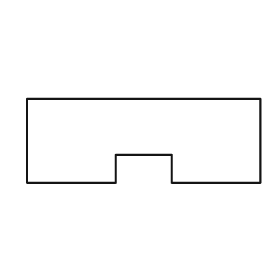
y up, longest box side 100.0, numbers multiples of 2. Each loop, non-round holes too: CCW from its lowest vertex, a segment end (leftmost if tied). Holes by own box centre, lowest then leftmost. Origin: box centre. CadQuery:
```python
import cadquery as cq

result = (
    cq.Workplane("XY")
    .moveTo(-50.0, -18.0)
    .lineTo(-12.0, -18.0)
    .lineTo(-12.0, -6.0)
    .lineTo(12.0, -6.0)
    .lineTo(12.0, -18.0)
    .lineTo(50.0, -18.0)
    .lineTo(50.0, 18.0)
    .lineTo(-50.0, 18.0)
    .close()
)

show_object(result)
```